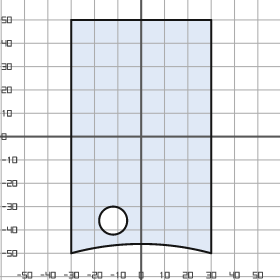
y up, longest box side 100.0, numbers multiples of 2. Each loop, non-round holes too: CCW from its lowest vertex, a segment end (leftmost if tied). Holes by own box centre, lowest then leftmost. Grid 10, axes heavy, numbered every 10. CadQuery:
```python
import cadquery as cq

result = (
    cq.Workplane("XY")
    .moveTo(-30.0, -50.0)
    .threePointArc((0.0, -46.0), (30.0, -50.0))
    .lineTo(30.0, 50.0)
    .lineTo(-30.0, 50.0)
    .close()
    .moveTo(-12.0, -36.0)
    .circle(6.0)
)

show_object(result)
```